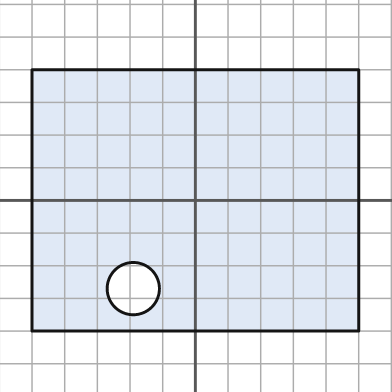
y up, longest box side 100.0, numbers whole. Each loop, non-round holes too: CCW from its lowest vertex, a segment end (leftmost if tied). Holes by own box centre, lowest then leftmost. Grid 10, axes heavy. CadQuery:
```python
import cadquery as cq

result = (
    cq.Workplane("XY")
    .moveTo(-50.0, -40.0)
    .lineTo(50.0, -40.0)
    .lineTo(50.0, 40.0)
    .lineTo(-50.0, 40.0)
    .close()
    .moveTo(-19.0, -27.0)
    .circle(8.0)
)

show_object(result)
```